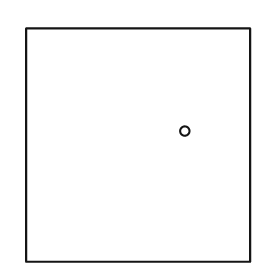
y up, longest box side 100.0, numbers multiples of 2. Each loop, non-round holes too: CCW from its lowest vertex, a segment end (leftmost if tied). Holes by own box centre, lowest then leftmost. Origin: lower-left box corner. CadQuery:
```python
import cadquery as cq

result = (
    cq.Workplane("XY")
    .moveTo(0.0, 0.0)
    .lineTo(96.0, 0.0)
    .lineTo(96.0, 100.0)
    .lineTo(0.0, 100.0)
    .close()
    .moveTo(68.0, 56.0)
    .circle(2.0)
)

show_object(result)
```